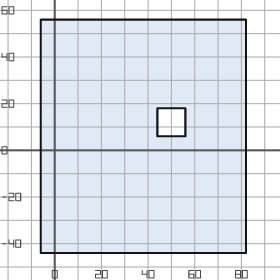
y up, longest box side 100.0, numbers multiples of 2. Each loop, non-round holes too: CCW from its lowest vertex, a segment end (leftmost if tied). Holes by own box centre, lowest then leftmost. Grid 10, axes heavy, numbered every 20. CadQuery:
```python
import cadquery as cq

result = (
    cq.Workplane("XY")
    .moveTo(-6.0, -44.0)
    .lineTo(82.0, -44.0)
    .lineTo(82.0, 56.0)
    .lineTo(-6.0, 56.0)
    .close()
    .moveTo(44.0, 6.0)
    .lineTo(56.0, 6.0)
    .lineTo(56.0, 18.0)
    .lineTo(44.0, 18.0)
    .close()
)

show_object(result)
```